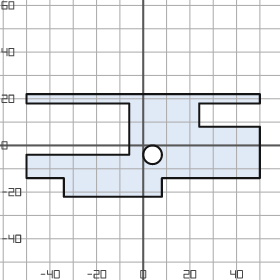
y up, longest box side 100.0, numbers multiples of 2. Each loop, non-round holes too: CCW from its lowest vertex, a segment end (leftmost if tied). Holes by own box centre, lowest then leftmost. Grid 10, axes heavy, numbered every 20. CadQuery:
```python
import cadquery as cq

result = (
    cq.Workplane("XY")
    .moveTo(-34.0, -22.0)
    .lineTo(8.0, -22.0)
    .lineTo(8.0, -14.0)
    .lineTo(50.0, -14.0)
    .lineTo(50.0, 8.0)
    .lineTo(24.0, 8.0)
    .lineTo(24.0, 18.0)
    .lineTo(50.0, 18.0)
    .lineTo(50.0, 22.0)
    .lineTo(-50.0, 22.0)
    .lineTo(-50.0, 18.0)
    .lineTo(-6.0, 18.0)
    .lineTo(-6.0, -4.0)
    .lineTo(-50.0, -4.0)
    .lineTo(-50.0, -14.0)
    .lineTo(-34.0, -14.0)
    .close()
    .moveTo(4.0, -4.0)
    .circle(4.0)
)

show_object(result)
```